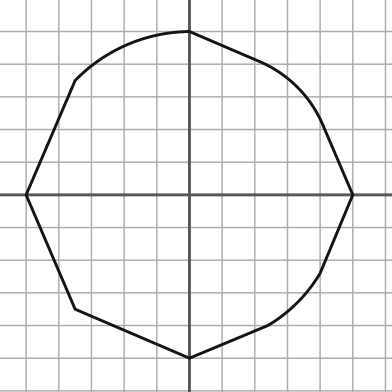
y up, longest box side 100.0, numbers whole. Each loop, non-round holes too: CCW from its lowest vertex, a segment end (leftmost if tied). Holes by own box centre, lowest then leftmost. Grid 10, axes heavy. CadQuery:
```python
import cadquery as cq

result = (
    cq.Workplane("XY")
    .moveTo(0.0, -50.0)
    .lineTo(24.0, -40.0)
    .threePointArc((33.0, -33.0), (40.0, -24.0))
    .lineTo(50.0, 0.0)
    .lineTo(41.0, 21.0)
    .threePointArc((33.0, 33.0), (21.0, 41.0))
    .lineTo(0.0, 50.0)
    .threePointArc((-19.0, 46.0), (-35.0, 35.0))
    .lineTo(-50.0, 0.0)
    .lineTo(-35.0, -35.0)
    .close()
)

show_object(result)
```